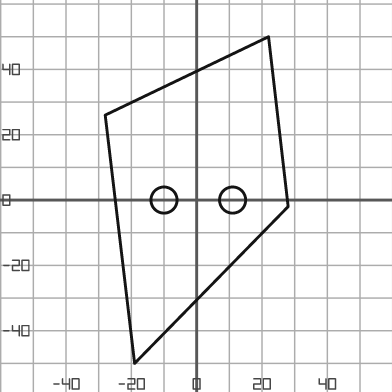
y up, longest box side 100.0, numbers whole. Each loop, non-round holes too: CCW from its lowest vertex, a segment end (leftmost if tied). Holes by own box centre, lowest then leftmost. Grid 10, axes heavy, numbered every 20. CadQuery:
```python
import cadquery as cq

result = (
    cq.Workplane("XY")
    .moveTo(-19.0, -50.0)
    .lineTo(28.0, -2.0)
    .lineTo(22.0, 50.0)
    .lineTo(-28.0, 26.0)
    .close()
    .moveTo(-10.0, 0.0)
    .circle(4.0)
    .moveTo(11.0, 0.0)
    .circle(4.0)
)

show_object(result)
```